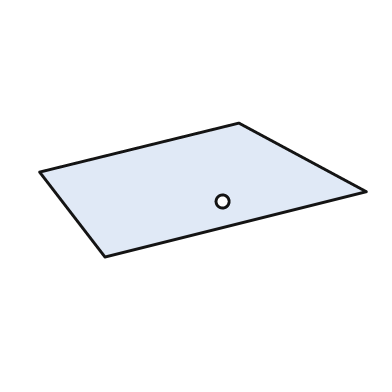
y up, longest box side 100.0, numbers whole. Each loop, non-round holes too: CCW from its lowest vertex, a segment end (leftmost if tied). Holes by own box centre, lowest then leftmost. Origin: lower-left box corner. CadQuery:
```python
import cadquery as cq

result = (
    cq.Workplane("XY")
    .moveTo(20.0, 0.0)
    .lineTo(100.0, 20.0)
    .lineTo(61.0, 41.0)
    .lineTo(0.0, 26.0)
    .close()
    .moveTo(56.0, 17.0)
    .circle(2.0)
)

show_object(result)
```